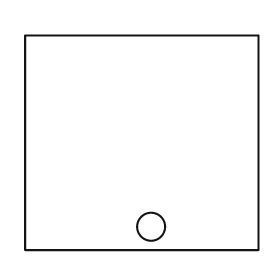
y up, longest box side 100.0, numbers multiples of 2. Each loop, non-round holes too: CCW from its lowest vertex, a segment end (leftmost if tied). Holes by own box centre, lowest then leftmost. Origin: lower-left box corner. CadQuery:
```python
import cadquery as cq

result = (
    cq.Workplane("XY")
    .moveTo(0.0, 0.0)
    .lineTo(100.0, 0.0)
    .lineTo(100.0, 92.0)
    .lineTo(0.0, 92.0)
    .close()
    .moveTo(54.0, 10.0)
    .circle(6.0)
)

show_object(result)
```